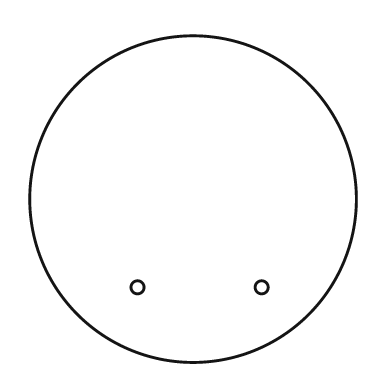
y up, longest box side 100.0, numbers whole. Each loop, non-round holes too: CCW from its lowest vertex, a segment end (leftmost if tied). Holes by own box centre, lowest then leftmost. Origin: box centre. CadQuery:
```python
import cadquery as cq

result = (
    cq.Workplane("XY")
    .moveTo(0.0, 0.0)
    .circle(50.0)
    .moveTo(-17.0, -27.0)
    .circle(2.0)
    .moveTo(21.0, -27.0)
    .circle(2.0)
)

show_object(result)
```